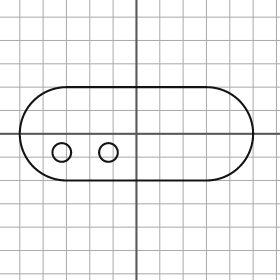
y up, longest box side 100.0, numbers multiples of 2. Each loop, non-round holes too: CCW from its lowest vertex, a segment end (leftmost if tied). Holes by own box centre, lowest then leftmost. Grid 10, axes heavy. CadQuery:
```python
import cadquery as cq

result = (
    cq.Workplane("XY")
    .moveTo(-30.0, -20.0)
    .lineTo(30.0, -20.0)
    .threePointArc((50.0, 0.0), (30.0, 20.0))
    .lineTo(-30.0, 20.0)
    .threePointArc((-50.0, 0.0), (-30.0, -20.0))
    .close()
    .moveTo(-32.0, -8.0)
    .circle(4.0)
    .moveTo(-12.0, -8.0)
    .circle(4.0)
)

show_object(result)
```